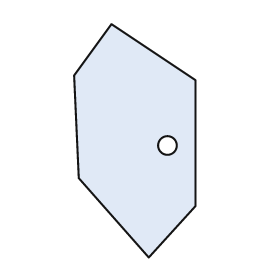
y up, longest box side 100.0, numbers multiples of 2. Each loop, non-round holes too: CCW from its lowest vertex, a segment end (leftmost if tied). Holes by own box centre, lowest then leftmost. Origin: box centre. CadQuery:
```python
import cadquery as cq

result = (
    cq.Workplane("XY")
    .moveTo(6.0, -50.0)
    .lineTo(26.0, -28.0)
    .lineTo(26.0, 26.0)
    .lineTo(-10.0, 50.0)
    .lineTo(-26.0, 28.0)
    .lineTo(-24.0, -16.0)
    .close()
    .moveTo(14.0, -2.0)
    .circle(4.0)
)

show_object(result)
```